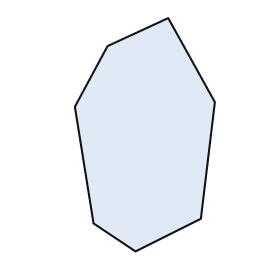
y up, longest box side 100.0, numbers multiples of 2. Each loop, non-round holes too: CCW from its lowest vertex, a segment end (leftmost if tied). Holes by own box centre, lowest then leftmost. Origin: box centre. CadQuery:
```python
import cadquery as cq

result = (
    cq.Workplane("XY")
    .moveTo(-4.0, -50.0)
    .lineTo(24.0, -36.0)
    .lineTo(30.0, 14.0)
    .lineTo(10.0, 50.0)
    .lineTo(-16.0, 38.0)
    .lineTo(-30.0, 12.0)
    .lineTo(-22.0, -38.0)
    .close()
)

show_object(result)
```